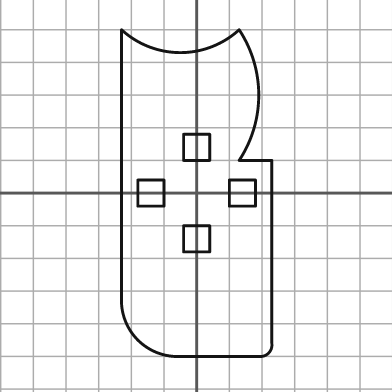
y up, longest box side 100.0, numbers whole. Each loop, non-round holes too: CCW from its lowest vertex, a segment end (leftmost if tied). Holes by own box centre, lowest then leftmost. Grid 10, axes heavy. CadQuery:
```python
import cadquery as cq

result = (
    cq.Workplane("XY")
    .moveTo(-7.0, -50.0)
    .lineTo(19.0, -50.0)
    .threePointArc((22.0, -49.0), (23.0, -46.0))
    .lineTo(23.0, 10.0)
    .lineTo(13.0, 10.0)
    .threePointArc((19.0, 30.0), (13.0, 50.0))
    .threePointArc((-5.0, 43.0), (-23.0, 50.0))
    .lineTo(-23.0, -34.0)
    .threePointArc((-18.0, -45.0), (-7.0, -50.0))
    .close()
    .moveTo(-4.0, -18.0)
    .lineTo(4.0, -18.0)
    .lineTo(4.0, -10.0)
    .lineTo(-4.0, -10.0)
    .close()
    .moveTo(-18.0, -4.0)
    .lineTo(-10.0, -4.0)
    .lineTo(-10.0, 4.0)
    .lineTo(-18.0, 4.0)
    .close()
    .moveTo(10.0, -4.0)
    .lineTo(18.0, -4.0)
    .lineTo(18.0, 4.0)
    .lineTo(10.0, 4.0)
    .close()
    .moveTo(-4.0, 10.0)
    .lineTo(4.0, 10.0)
    .lineTo(4.0, 18.0)
    .lineTo(-4.0, 18.0)
    .close()
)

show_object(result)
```